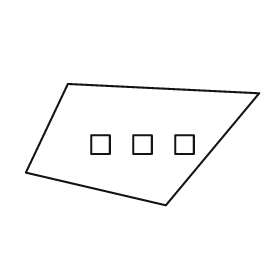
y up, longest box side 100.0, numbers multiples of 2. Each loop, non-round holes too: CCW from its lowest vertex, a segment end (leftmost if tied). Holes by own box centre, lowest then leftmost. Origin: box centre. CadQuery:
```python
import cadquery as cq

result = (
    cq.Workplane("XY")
    .moveTo(10.0, -26.0)
    .lineTo(50.0, 22.0)
    .lineTo(-32.0, 26.0)
    .lineTo(-50.0, -12.0)
    .close()
    .moveTo(-22.0, -4.0)
    .lineTo(-14.0, -4.0)
    .lineTo(-14.0, 4.0)
    .lineTo(-22.0, 4.0)
    .close()
    .moveTo(-4.0, -4.0)
    .lineTo(4.0, -4.0)
    .lineTo(4.0, 4.0)
    .lineTo(-4.0, 4.0)
    .close()
    .moveTo(14.0, -4.0)
    .lineTo(22.0, -4.0)
    .lineTo(22.0, 4.0)
    .lineTo(14.0, 4.0)
    .close()
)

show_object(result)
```